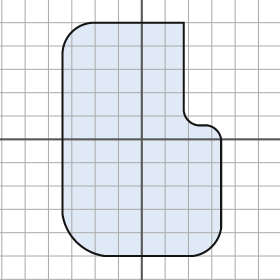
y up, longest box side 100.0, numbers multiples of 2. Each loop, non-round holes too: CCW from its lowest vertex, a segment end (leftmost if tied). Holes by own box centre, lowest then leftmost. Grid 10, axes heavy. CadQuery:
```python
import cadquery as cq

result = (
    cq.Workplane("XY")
    .moveTo(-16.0, -50.0)
    .lineTo(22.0, -50.0)
    .threePointArc((30.0, -46.0), (34.0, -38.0))
    .lineTo(34.0, 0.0)
    .threePointArc((32.0, 4.0), (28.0, 6.0))
    .lineTo(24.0, 6.0)
    .threePointArc((20.0, 8.0), (18.0, 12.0))
    .lineTo(18.0, 50.0)
    .lineTo(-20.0, 50.0)
    .threePointArc((-30.0, 46.0), (-34.0, 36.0))
    .lineTo(-34.0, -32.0)
    .threePointArc((-28.0, -44.0), (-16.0, -50.0))
    .close()
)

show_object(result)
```